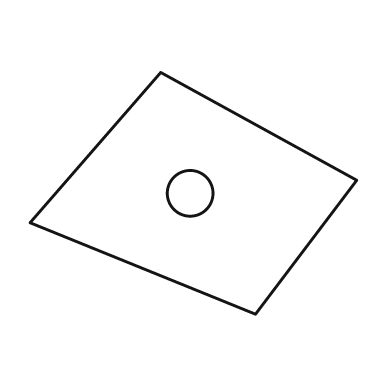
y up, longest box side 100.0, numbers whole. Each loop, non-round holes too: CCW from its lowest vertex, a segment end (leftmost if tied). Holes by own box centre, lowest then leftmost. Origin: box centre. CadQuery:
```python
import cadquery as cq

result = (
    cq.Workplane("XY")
    .moveTo(19.0, -37.0)
    .lineTo(50.0, 4.0)
    .lineTo(-10.0, 37.0)
    .lineTo(-50.0, -9.0)
    .close()
    .moveTo(-1.0, 0.0)
    .circle(7.0)
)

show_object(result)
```